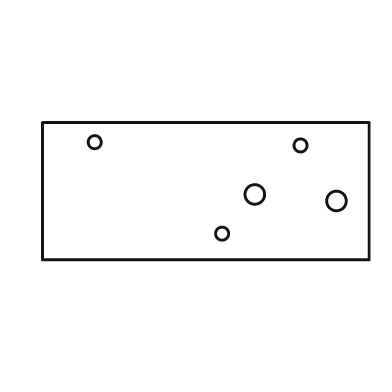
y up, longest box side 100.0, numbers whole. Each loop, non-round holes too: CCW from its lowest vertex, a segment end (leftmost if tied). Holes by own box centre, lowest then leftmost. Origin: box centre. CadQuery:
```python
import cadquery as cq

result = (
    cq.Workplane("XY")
    .moveTo(-50.0, -21.0)
    .lineTo(50.0, -21.0)
    .lineTo(50.0, 21.0)
    .lineTo(-50.0, 21.0)
    .close()
    .moveTo(5.0, -13.0)
    .circle(2.0)
    .moveTo(40.0, -3.0)
    .circle(3.0)
    .moveTo(15.0, -1.0)
    .circle(3.0)
    .moveTo(29.0, 14.0)
    .circle(2.0)
    .moveTo(-34.0, 15.0)
    .circle(2.0)
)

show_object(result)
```